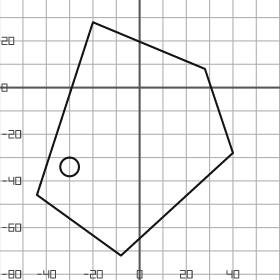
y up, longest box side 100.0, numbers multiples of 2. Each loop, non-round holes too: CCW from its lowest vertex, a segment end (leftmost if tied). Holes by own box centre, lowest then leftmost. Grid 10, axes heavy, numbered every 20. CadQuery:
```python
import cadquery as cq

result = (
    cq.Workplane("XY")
    .moveTo(-8.0, -72.0)
    .lineTo(40.0, -28.0)
    .lineTo(28.0, 8.0)
    .lineTo(-20.0, 28.0)
    .lineTo(-44.0, -46.0)
    .close()
    .moveTo(-30.0, -34.0)
    .circle(4.0)
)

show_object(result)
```